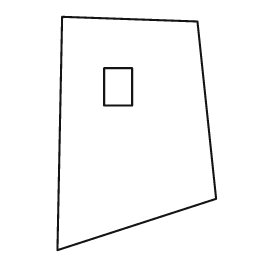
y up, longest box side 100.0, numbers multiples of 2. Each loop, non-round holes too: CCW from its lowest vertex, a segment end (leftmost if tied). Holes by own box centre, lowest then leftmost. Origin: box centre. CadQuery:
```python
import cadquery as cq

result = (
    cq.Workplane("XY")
    .moveTo(-34.0, -50.0)
    .lineTo(34.0, -28.0)
    .lineTo(26.0, 48.0)
    .lineTo(-32.0, 50.0)
    .close()
    .moveTo(-14.0, 12.0)
    .lineTo(-2.0, 12.0)
    .lineTo(-2.0, 28.0)
    .lineTo(-14.0, 28.0)
    .close()
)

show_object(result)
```